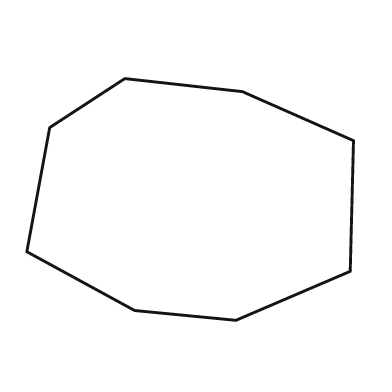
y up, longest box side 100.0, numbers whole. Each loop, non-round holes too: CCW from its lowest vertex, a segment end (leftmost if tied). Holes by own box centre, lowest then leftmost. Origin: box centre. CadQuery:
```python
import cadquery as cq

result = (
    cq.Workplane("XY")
    .moveTo(14.0, -37.0)
    .lineTo(49.0, -22.0)
    .lineTo(50.0, 18.0)
    .lineTo(16.0, 33.0)
    .lineTo(-20.0, 37.0)
    .lineTo(-43.0, 22.0)
    .lineTo(-50.0, -16.0)
    .lineTo(-17.0, -34.0)
    .close()
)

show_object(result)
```